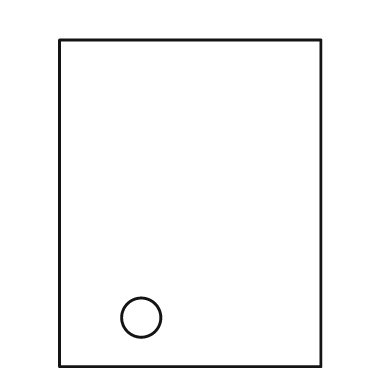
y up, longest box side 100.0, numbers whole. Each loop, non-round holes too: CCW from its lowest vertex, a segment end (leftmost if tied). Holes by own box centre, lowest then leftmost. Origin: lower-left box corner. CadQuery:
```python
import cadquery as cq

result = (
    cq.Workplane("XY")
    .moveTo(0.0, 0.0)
    .lineTo(80.0, 0.0)
    .lineTo(80.0, 100.0)
    .lineTo(0.0, 100.0)
    .close()
    .moveTo(25.0, 15.0)
    .circle(6.0)
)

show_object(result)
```